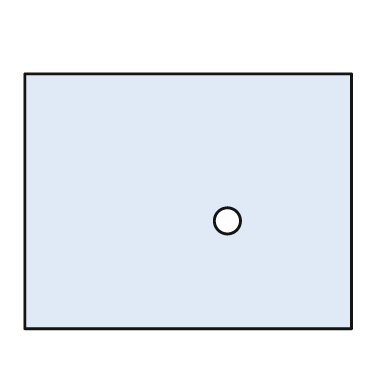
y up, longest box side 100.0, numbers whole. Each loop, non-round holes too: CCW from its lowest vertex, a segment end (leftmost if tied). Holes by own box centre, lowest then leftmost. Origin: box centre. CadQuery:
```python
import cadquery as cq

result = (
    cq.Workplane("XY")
    .moveTo(-50.0, -39.0)
    .lineTo(50.0, -39.0)
    .lineTo(50.0, 39.0)
    .lineTo(-50.0, 39.0)
    .close()
    .moveTo(12.0, -6.0)
    .circle(4.0)
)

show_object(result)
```